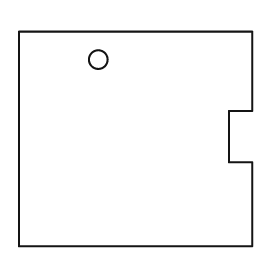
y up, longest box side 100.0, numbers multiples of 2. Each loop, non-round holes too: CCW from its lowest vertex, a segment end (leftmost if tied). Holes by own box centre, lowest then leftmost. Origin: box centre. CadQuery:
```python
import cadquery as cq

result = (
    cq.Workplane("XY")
    .moveTo(-50.0, -46.0)
    .lineTo(50.0, -46.0)
    .lineTo(50.0, -10.0)
    .lineTo(40.0, -10.0)
    .lineTo(40.0, 12.0)
    .lineTo(50.0, 12.0)
    .lineTo(50.0, 46.0)
    .lineTo(-50.0, 46.0)
    .close()
    .moveTo(-16.0, 34.0)
    .circle(4.0)
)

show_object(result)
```